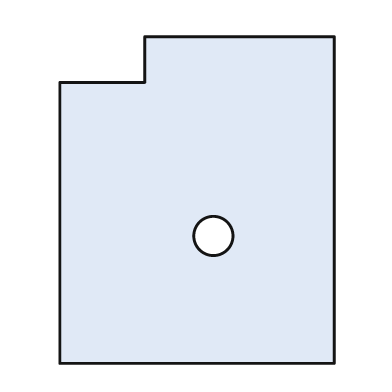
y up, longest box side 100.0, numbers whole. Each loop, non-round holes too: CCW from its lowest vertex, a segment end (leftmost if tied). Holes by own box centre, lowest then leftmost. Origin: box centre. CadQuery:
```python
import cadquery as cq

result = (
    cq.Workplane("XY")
    .moveTo(-42.0, -50.0)
    .lineTo(42.0, -50.0)
    .lineTo(42.0, 50.0)
    .lineTo(-16.0, 50.0)
    .lineTo(-16.0, 36.0)
    .lineTo(-42.0, 36.0)
    .close()
    .moveTo(5.0, -11.0)
    .circle(6.0)
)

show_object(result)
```